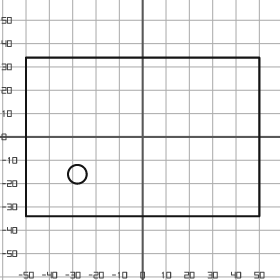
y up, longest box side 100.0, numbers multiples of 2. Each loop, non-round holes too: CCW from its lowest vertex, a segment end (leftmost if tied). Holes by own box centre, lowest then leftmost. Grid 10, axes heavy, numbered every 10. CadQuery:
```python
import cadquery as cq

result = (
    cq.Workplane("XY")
    .moveTo(-50.0, -34.0)
    .lineTo(50.0, -34.0)
    .lineTo(50.0, 34.0)
    .lineTo(-50.0, 34.0)
    .close()
    .moveTo(-28.0, -16.0)
    .circle(4.0)
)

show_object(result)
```